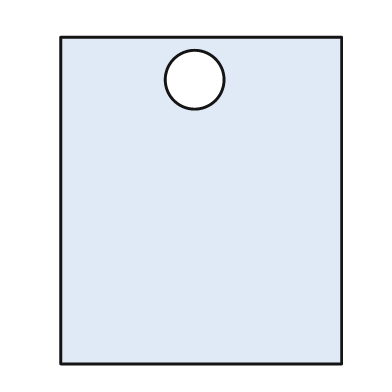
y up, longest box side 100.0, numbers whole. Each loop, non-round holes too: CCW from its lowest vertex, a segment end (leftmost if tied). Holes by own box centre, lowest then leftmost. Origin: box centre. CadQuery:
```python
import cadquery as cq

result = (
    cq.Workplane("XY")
    .moveTo(-43.0, -50.0)
    .lineTo(43.0, -50.0)
    .lineTo(43.0, 50.0)
    .lineTo(-43.0, 50.0)
    .close()
    .moveTo(-2.0, 37.0)
    .circle(9.0)
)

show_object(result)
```